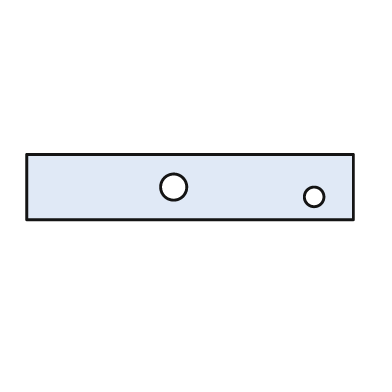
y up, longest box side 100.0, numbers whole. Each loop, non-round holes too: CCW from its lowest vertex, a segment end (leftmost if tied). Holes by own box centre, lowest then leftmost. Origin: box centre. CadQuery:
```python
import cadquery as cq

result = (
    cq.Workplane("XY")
    .moveTo(-50.0, -10.0)
    .lineTo(50.0, -10.0)
    .lineTo(50.0, 10.0)
    .lineTo(-50.0, 10.0)
    .close()
    .moveTo(38.0, -3.0)
    .circle(3.0)
    .moveTo(-5.0, 0.0)
    .circle(4.0)
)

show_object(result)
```